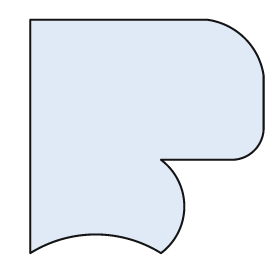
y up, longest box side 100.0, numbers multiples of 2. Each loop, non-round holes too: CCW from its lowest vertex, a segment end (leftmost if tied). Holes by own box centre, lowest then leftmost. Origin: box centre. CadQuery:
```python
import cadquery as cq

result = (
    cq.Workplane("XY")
    .moveTo(-50.0, -50.0)
    .threePointArc((-22.0, -42.0), (6.0, -50.0))
    .threePointArc((16.0, -30.0), (6.0, -10.0))
    .lineTo(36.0, -10.0)
    .threePointArc((46.0, -6.0), (50.0, 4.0))
    .lineTo(50.0, 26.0)
    .threePointArc((42.0, 42.0), (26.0, 50.0))
    .lineTo(-50.0, 50.0)
    .close()
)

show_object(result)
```